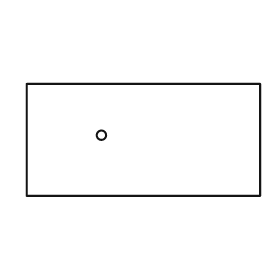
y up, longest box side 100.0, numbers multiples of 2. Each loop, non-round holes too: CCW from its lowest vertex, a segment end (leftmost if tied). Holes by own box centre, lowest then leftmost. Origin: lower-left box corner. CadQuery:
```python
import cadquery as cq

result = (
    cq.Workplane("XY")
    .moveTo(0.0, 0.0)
    .lineTo(100.0, 0.0)
    .lineTo(100.0, 48.0)
    .lineTo(0.0, 48.0)
    .close()
    .moveTo(32.0, 26.0)
    .circle(2.0)
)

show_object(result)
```